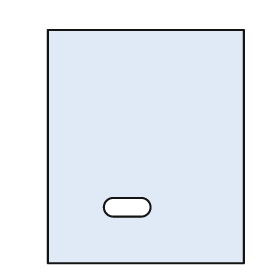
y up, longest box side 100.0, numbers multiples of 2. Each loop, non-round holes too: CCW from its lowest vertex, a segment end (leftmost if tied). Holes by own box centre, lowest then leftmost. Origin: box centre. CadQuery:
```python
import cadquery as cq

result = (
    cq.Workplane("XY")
    .moveTo(-42.0, -50.0)
    .lineTo(42.0, -50.0)
    .lineTo(42.0, 50.0)
    .lineTo(-42.0, 50.0)
    .close()
    .moveTo(-14.0, -30.0)
    .lineTo(-2.0, -30.0)
    .threePointArc((2.0, -26.0), (-2.0, -22.0))
    .lineTo(-14.0, -22.0)
    .threePointArc((-18.0, -26.0), (-14.0, -30.0))
    .close()
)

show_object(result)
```